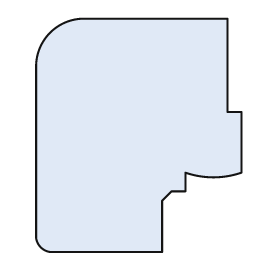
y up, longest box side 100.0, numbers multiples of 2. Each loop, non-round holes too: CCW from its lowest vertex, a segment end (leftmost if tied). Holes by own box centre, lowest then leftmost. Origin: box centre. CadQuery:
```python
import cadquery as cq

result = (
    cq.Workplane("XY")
    .moveTo(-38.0, -50.0)
    .lineTo(10.0, -50.0)
    .lineTo(10.0, -28.0)
    .lineTo(14.0, -24.0)
    .lineTo(20.0, -24.0)
    .lineTo(20.0, -16.0)
    .threePointArc((32.0, -18.0), (44.0, -16.0))
    .lineTo(44.0, 10.0)
    .lineTo(38.0, 10.0)
    .lineTo(38.0, 50.0)
    .lineTo(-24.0, 50.0)
    .threePointArc((-38.0, 44.0), (-44.0, 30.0))
    .lineTo(-44.0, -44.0)
    .threePointArc((-42.0, -48.0), (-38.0, -50.0))
    .close()
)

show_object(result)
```